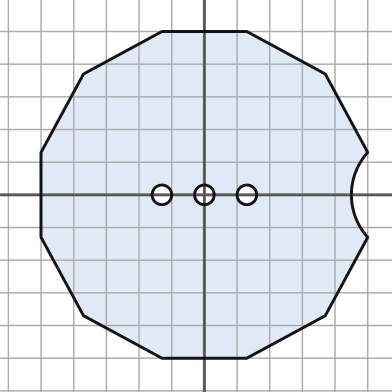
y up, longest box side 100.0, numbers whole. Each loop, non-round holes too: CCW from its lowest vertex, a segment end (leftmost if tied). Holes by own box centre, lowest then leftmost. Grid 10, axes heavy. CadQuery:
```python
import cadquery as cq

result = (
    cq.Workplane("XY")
    .moveTo(-13.0, -50.0)
    .lineTo(13.0, -50.0)
    .lineTo(37.0, -37.0)
    .lineTo(50.0, -13.0)
    .threePointArc((45.0, 0.0), (50.0, 13.0))
    .lineTo(37.0, 37.0)
    .lineTo(13.0, 50.0)
    .lineTo(-13.0, 50.0)
    .lineTo(-37.0, 37.0)
    .lineTo(-50.0, 13.0)
    .lineTo(-50.0, -13.0)
    .lineTo(-37.0, -37.0)
    .close()
    .moveTo(-13.0, 0.0)
    .circle(3.0)
    .moveTo(0.0, 0.0)
    .circle(3.0)
    .moveTo(13.0, 0.0)
    .circle(3.0)
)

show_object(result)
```